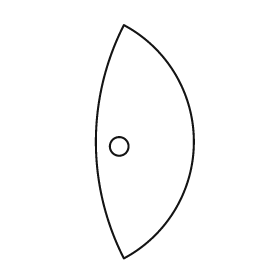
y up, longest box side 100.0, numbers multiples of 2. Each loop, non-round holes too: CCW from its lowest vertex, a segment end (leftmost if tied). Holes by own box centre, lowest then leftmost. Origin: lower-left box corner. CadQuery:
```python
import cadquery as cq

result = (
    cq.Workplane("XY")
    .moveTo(12.0, 0.0)
    .threePointArc((42.0, 50.0), (12.0, 100.0))
    .threePointArc((0.0, 50.0), (12.0, 0.0))
    .close()
    .moveTo(10.0, 48.0)
    .circle(4.0)
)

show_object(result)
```